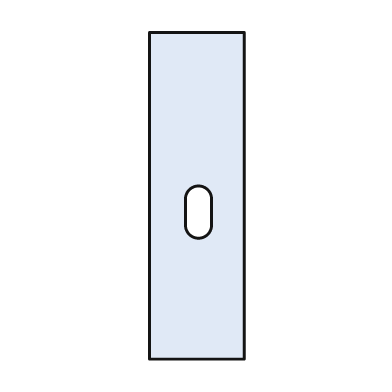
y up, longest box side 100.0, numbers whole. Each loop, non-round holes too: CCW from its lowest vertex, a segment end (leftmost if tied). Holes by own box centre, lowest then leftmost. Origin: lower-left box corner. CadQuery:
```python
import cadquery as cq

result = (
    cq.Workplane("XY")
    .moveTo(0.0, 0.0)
    .lineTo(29.0, 0.0)
    .lineTo(29.0, 100.0)
    .lineTo(0.0, 100.0)
    .close()
    .moveTo(11.0, 41.0)
    .threePointArc((15.0, 37.0), (19.0, 41.0))
    .lineTo(19.0, 49.0)
    .threePointArc((15.0, 53.0), (11.0, 49.0))
    .close()
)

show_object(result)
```